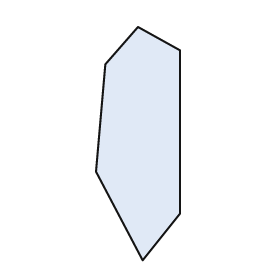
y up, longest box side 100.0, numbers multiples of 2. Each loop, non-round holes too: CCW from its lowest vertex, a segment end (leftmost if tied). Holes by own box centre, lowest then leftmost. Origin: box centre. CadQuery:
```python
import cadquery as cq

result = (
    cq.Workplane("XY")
    .moveTo(2.0, -50.0)
    .lineTo(18.0, -30.0)
    .lineTo(18.0, 40.0)
    .lineTo(0.0, 50.0)
    .lineTo(-14.0, 34.0)
    .lineTo(-18.0, -12.0)
    .close()
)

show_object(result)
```